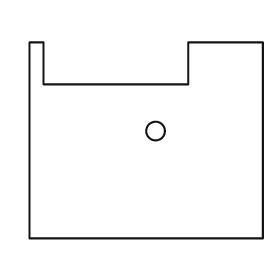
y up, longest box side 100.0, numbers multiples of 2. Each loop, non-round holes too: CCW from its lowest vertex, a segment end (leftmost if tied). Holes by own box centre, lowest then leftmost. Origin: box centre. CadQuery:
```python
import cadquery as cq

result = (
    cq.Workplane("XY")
    .moveTo(-50.0, -42.0)
    .lineTo(50.0, -42.0)
    .lineTo(50.0, 42.0)
    .lineTo(18.0, 42.0)
    .lineTo(18.0, 24.0)
    .lineTo(-44.0, 24.0)
    .lineTo(-44.0, 42.0)
    .lineTo(-50.0, 42.0)
    .close()
    .moveTo(4.0, 4.0)
    .circle(4.0)
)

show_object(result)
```